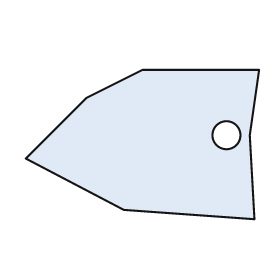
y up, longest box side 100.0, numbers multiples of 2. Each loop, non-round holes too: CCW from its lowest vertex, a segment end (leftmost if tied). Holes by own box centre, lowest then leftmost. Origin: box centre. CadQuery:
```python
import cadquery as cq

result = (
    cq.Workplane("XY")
    .moveTo(48.0, -32.0)
    .lineTo(46.0, 4.0)
    .lineTo(50.0, 32.0)
    .lineTo(0.0, 32.0)
    .lineTo(-24.0, 20.0)
    .lineTo(-50.0, -6.0)
    .lineTo(-8.0, -28.0)
    .close()
    .moveTo(36.0, 4.0)
    .circle(6.0)
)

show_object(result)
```